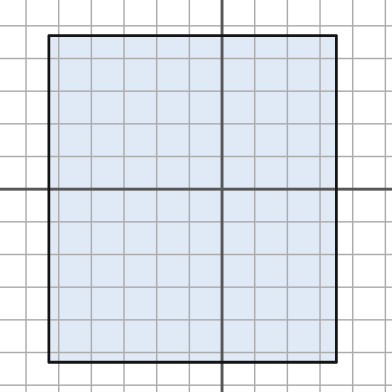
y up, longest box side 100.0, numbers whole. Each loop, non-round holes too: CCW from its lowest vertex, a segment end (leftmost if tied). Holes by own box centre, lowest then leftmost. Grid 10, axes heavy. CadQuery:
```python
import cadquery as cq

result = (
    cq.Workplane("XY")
    .moveTo(-53.0, -53.0)
    .lineTo(35.0, -53.0)
    .lineTo(35.0, 47.0)
    .lineTo(-53.0, 47.0)
    .close()
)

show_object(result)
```